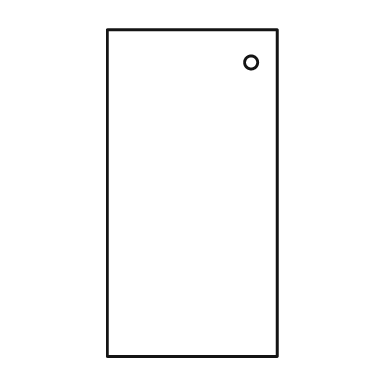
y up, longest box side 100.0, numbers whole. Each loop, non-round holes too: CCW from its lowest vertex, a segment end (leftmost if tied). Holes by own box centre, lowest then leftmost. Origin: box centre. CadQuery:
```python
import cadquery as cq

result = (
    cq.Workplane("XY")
    .moveTo(-26.0, -50.0)
    .lineTo(26.0, -50.0)
    .lineTo(26.0, 50.0)
    .lineTo(-26.0, 50.0)
    .close()
    .moveTo(18.0, 40.0)
    .circle(2.0)
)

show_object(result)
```